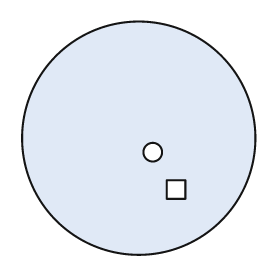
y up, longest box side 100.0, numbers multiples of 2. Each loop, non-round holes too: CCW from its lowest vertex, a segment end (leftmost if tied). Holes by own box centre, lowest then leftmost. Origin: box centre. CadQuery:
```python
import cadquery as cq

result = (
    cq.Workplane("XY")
    .moveTo(0.0, 0.0)
    .circle(50.0)
    .moveTo(12.0, -26.0)
    .lineTo(20.0, -26.0)
    .lineTo(20.0, -18.0)
    .lineTo(12.0, -18.0)
    .close()
    .moveTo(6.0, -6.0)
    .circle(4.0)
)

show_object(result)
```